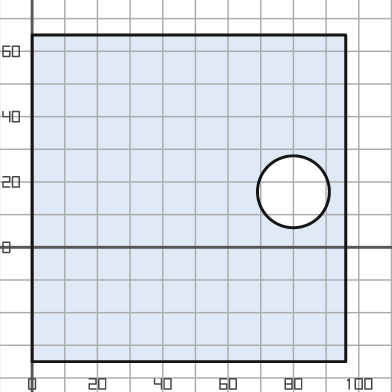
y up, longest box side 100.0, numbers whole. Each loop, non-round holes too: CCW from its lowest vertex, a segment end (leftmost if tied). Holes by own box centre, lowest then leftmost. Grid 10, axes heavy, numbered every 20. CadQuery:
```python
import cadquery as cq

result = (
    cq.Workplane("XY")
    .moveTo(0.0, -35.0)
    .lineTo(96.0, -35.0)
    .lineTo(96.0, 65.0)
    .lineTo(0.0, 65.0)
    .close()
    .moveTo(80.0, 17.0)
    .circle(11.0)
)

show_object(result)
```